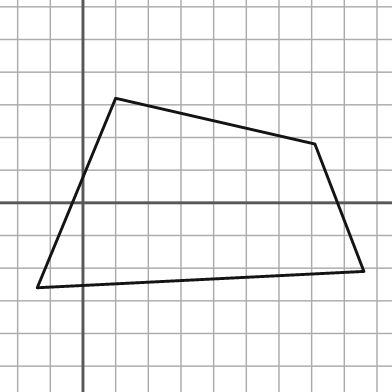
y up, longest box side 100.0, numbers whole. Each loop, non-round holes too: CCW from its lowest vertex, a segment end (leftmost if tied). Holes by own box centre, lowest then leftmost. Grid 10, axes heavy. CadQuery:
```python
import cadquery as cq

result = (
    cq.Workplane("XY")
    .moveTo(-14.0, -26.0)
    .lineTo(86.0, -21.0)
    .lineTo(71.0, 18.0)
    .lineTo(10.0, 32.0)
    .close()
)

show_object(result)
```